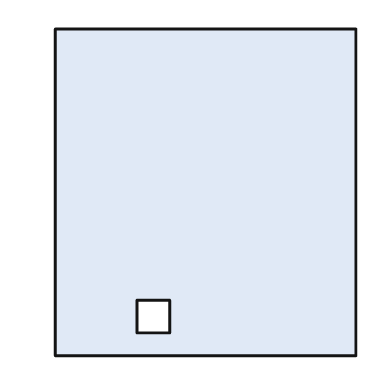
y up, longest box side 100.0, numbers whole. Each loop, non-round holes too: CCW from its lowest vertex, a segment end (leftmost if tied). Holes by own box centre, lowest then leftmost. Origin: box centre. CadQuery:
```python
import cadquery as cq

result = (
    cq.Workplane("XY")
    .moveTo(-46.0, -50.0)
    .lineTo(46.0, -50.0)
    .lineTo(46.0, 50.0)
    .lineTo(-46.0, 50.0)
    .close()
    .moveTo(-21.0, -43.0)
    .lineTo(-11.0, -43.0)
    .lineTo(-11.0, -33.0)
    .lineTo(-21.0, -33.0)
    .close()
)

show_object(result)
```